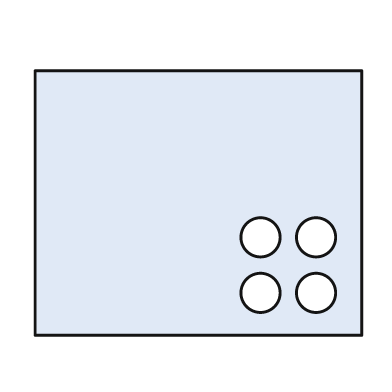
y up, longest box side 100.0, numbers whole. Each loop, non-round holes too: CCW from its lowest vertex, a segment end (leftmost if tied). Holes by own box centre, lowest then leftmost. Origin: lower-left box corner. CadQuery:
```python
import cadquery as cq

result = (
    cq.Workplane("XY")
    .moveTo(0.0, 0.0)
    .lineTo(100.0, 0.0)
    .lineTo(100.0, 81.0)
    .lineTo(0.0, 81.0)
    .close()
    .moveTo(69.0, 13.0)
    .circle(6.0)
    .moveTo(86.0, 13.0)
    .circle(6.0)
    .moveTo(69.0, 30.0)
    .circle(6.0)
    .moveTo(86.0, 30.0)
    .circle(6.0)
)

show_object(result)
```